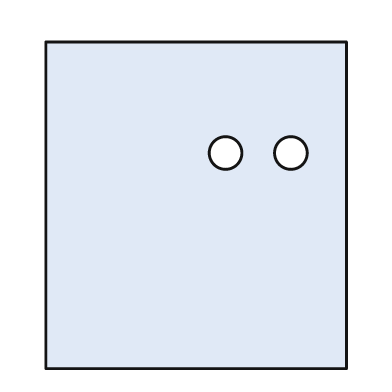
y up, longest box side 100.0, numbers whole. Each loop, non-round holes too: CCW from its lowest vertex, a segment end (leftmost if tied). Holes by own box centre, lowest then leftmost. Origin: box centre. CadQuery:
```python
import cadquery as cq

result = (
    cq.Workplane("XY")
    .moveTo(-46.0, -50.0)
    .lineTo(46.0, -50.0)
    .lineTo(46.0, 50.0)
    .lineTo(-46.0, 50.0)
    .close()
    .moveTo(9.0, 16.0)
    .circle(5.0)
    .moveTo(29.0, 16.0)
    .circle(5.0)
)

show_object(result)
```